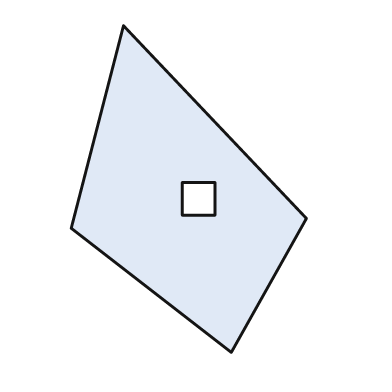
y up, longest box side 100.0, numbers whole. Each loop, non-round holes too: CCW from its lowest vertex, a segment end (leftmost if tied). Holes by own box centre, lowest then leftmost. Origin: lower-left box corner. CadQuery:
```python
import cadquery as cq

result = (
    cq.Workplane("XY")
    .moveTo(49.0, 0.0)
    .lineTo(72.0, 41.0)
    .lineTo(16.0, 100.0)
    .lineTo(0.0, 38.0)
    .close()
    .moveTo(34.0, 42.0)
    .lineTo(44.0, 42.0)
    .lineTo(44.0, 52.0)
    .lineTo(34.0, 52.0)
    .close()
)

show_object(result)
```